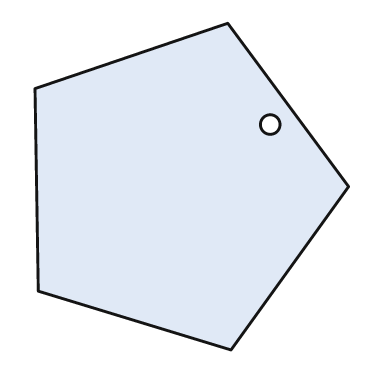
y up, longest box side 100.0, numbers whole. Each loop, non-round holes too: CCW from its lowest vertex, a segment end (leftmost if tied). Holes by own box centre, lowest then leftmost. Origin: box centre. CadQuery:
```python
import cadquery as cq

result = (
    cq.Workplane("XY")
    .moveTo(12.0, -50.0)
    .lineTo(48.0, 0.0)
    .lineTo(11.0, 50.0)
    .lineTo(-48.0, 30.0)
    .lineTo(-47.0, -32.0)
    .close()
    .moveTo(24.0, 19.0)
    .circle(3.0)
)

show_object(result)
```